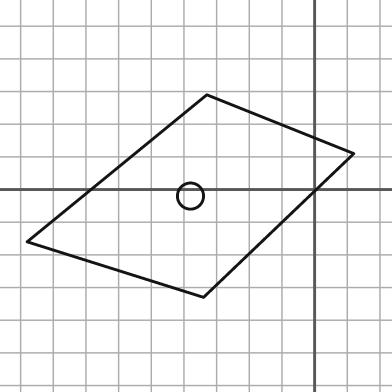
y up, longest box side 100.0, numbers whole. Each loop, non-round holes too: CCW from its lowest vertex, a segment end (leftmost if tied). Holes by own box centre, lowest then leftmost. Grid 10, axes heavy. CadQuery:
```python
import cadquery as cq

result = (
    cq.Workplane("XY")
    .moveTo(-34.0, -33.0)
    .lineTo(12.0, 11.0)
    .lineTo(-33.0, 29.0)
    .lineTo(-88.0, -16.0)
    .close()
    .moveTo(-38.0, -2.0)
    .circle(4.0)
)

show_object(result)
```